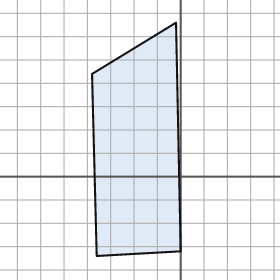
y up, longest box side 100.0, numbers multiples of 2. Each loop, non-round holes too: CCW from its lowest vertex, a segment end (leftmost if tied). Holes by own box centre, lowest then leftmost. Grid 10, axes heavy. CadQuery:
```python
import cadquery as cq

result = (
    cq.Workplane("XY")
    .moveTo(-36.0, -34.0)
    .lineTo(0.0, -32.0)
    .lineTo(-2.0, 66.0)
    .lineTo(-38.0, 44.0)
    .close()
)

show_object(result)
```